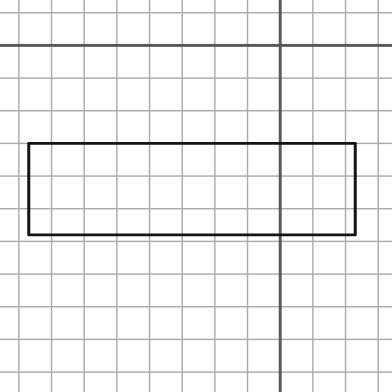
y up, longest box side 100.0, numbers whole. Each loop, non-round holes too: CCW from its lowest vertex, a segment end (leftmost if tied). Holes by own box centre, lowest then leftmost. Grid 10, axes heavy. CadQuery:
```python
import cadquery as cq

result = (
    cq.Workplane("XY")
    .moveTo(-77.0, -58.0)
    .lineTo(23.0, -58.0)
    .lineTo(23.0, -30.0)
    .lineTo(-77.0, -30.0)
    .close()
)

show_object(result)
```